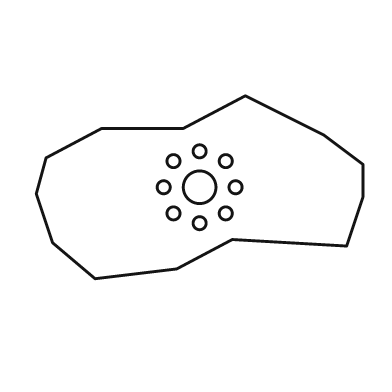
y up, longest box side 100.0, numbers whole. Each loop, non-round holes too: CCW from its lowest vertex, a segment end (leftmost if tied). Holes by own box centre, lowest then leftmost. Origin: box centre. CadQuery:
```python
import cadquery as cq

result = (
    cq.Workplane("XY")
    .moveTo(-32.0, -28.0)
    .lineTo(-7.0, -25.0)
    .lineTo(10.0, -16.0)
    .lineTo(45.0, -18.0)
    .lineTo(50.0, -3.0)
    .lineTo(50.0, 7.0)
    .lineTo(38.0, 16.0)
    .lineTo(14.0, 28.0)
    .lineTo(-5.0, 18.0)
    .lineTo(-30.0, 18.0)
    .lineTo(-47.0, 9.0)
    .lineTo(-50.0, -2.0)
    .lineTo(-45.0, -17.0)
    .close()
    .moveTo(0.0, -11.0)
    .circle(2.0)
    .moveTo(-8.0, -8.0)
    .circle(2.0)
    .moveTo(8.0, -8.0)
    .circle(2.0)
    .moveTo(-11.0, 0.0)
    .circle(2.0)
    .moveTo(0.0, 0.0)
    .circle(5.0)
    .moveTo(11.0, 0.0)
    .circle(2.0)
    .moveTo(-8.0, 8.0)
    .circle(2.0)
    .moveTo(8.0, 8.0)
    .circle(2.0)
    .moveTo(0.0, 11.0)
    .circle(2.0)
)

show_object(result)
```